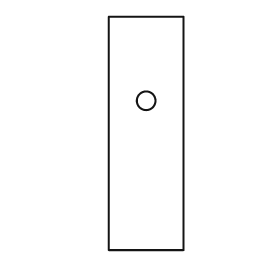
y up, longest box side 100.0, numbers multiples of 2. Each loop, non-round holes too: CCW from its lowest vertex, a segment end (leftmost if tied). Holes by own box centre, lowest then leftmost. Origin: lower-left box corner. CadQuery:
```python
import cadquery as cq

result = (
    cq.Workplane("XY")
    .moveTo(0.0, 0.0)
    .lineTo(32.0, 0.0)
    .lineTo(32.0, 100.0)
    .lineTo(0.0, 100.0)
    .close()
    .moveTo(16.0, 64.0)
    .circle(4.0)
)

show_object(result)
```